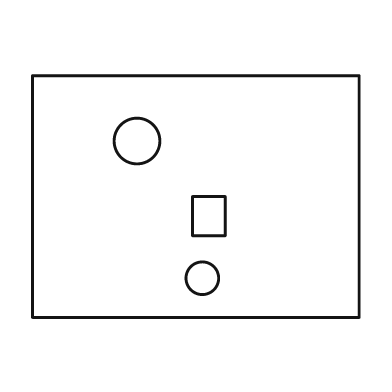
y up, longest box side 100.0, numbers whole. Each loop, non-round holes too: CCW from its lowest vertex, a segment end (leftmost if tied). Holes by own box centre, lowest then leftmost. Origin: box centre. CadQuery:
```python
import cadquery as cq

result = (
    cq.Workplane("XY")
    .moveTo(-50.0, -37.0)
    .lineTo(50.0, -37.0)
    .lineTo(50.0, 37.0)
    .lineTo(-50.0, 37.0)
    .close()
    .moveTo(2.0, -25.0)
    .circle(5.0)
    .moveTo(-1.0, -12.0)
    .lineTo(9.0, -12.0)
    .lineTo(9.0, 0.0)
    .lineTo(-1.0, 0.0)
    .close()
    .moveTo(-18.0, 17.0)
    .circle(7.0)
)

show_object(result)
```